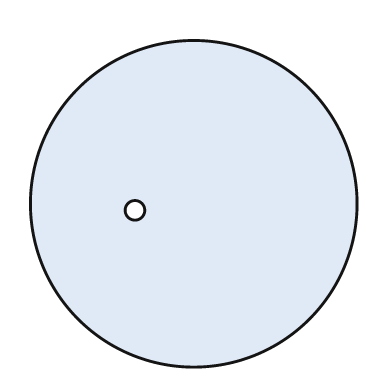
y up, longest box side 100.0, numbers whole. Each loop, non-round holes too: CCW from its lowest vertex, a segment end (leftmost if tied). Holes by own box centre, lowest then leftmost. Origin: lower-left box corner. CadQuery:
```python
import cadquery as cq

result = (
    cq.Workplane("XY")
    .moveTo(50.0, 50.0)
    .circle(50.0)
    .moveTo(32.0, 48.0)
    .circle(3.0)
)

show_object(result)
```